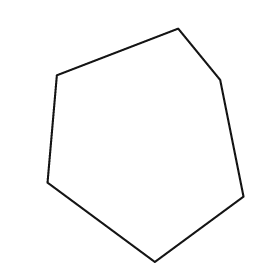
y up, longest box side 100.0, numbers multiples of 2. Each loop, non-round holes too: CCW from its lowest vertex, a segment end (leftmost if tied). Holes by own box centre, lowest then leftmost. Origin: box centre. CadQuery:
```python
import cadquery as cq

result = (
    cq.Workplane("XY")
    .moveTo(4.0, -50.0)
    .lineTo(42.0, -22.0)
    .lineTo(32.0, 28.0)
    .lineTo(14.0, 50.0)
    .lineTo(-38.0, 30.0)
    .lineTo(-42.0, -16.0)
    .close()
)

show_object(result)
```